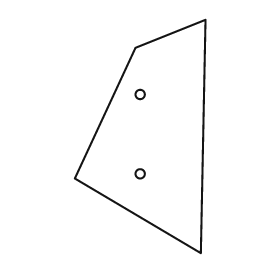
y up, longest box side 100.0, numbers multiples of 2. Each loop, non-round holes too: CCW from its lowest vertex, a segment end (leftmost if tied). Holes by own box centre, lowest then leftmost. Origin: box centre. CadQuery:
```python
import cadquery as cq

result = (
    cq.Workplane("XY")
    .moveTo(26.0, -50.0)
    .lineTo(28.0, 50.0)
    .lineTo(-2.0, 38.0)
    .lineTo(-28.0, -18.0)
    .close()
    .moveTo(0.0, -16.0)
    .circle(2.0)
    .moveTo(0.0, 18.0)
    .circle(2.0)
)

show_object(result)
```